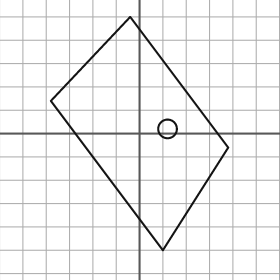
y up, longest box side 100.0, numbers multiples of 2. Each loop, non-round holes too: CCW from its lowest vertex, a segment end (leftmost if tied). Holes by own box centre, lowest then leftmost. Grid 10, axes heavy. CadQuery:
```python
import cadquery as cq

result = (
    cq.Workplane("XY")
    .moveTo(10.0, -50.0)
    .lineTo(38.0, -6.0)
    .lineTo(-4.0, 50.0)
    .lineTo(-38.0, 14.0)
    .close()
    .moveTo(12.0, 2.0)
    .circle(4.0)
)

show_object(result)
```